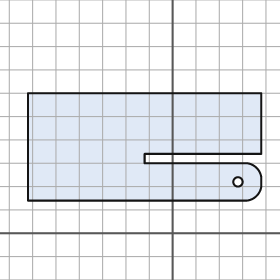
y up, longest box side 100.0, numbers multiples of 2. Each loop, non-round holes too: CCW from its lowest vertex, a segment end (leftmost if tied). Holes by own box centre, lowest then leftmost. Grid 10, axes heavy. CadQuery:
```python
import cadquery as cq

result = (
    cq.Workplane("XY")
    .moveTo(-62.0, 14.0)
    .lineTo(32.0, 14.0)
    .threePointArc((36.0, 16.0), (38.0, 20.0))
    .lineTo(38.0, 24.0)
    .threePointArc((36.0, 28.0), (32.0, 30.0))
    .lineTo(-12.0, 30.0)
    .lineTo(-12.0, 34.0)
    .lineTo(38.0, 34.0)
    .lineTo(38.0, 60.0)
    .lineTo(-62.0, 60.0)
    .close()
    .moveTo(28.0, 22.0)
    .circle(2.0)
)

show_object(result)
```